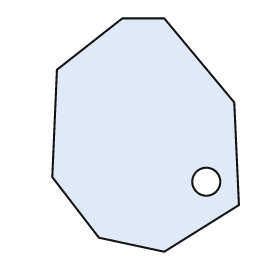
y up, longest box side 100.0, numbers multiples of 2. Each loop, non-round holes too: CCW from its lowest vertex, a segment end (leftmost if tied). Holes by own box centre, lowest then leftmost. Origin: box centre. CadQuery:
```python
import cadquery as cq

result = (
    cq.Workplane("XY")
    .moveTo(8.0, -50.0)
    .lineTo(40.0, -30.0)
    .lineTo(38.0, 14.0)
    .lineTo(8.0, 50.0)
    .lineTo(-10.0, 50.0)
    .lineTo(-38.0, 28.0)
    .lineTo(-40.0, -18.0)
    .lineTo(-20.0, -44.0)
    .close()
    .moveTo(26.0, -20.0)
    .circle(6.0)
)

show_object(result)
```